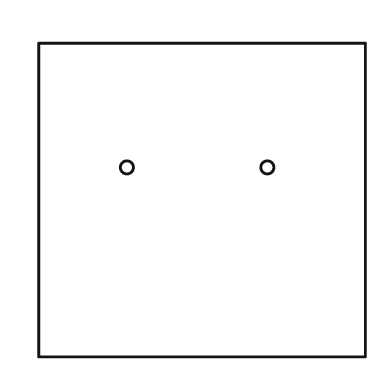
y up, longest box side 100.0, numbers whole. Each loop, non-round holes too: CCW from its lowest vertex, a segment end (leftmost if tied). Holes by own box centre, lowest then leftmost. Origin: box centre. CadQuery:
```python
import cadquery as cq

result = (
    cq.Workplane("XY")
    .moveTo(-50.0, -48.0)
    .lineTo(50.0, -48.0)
    .lineTo(50.0, 48.0)
    .lineTo(-50.0, 48.0)
    .close()
    .moveTo(-23.0, 10.0)
    .circle(2.0)
    .moveTo(20.0, 10.0)
    .circle(2.0)
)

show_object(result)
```